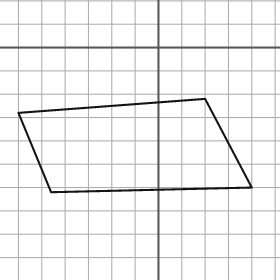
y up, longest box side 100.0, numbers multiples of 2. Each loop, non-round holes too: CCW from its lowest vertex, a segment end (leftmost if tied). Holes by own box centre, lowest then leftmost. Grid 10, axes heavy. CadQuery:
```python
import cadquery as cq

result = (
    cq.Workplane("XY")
    .moveTo(-46.0, -62.0)
    .lineTo(40.0, -60.0)
    .lineTo(20.0, -22.0)
    .lineTo(-60.0, -28.0)
    .close()
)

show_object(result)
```